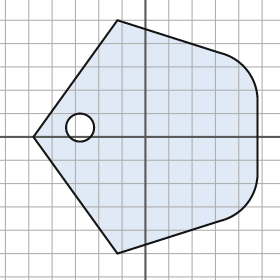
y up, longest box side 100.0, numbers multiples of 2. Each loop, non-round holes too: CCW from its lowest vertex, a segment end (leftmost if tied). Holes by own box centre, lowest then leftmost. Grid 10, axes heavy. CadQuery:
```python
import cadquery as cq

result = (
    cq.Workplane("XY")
    .moveTo(-12.0, -50.0)
    .lineTo(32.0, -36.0)
    .threePointArc((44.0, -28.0), (48.0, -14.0))
    .lineTo(48.0, 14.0)
    .threePointArc((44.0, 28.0), (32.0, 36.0))
    .lineTo(-12.0, 50.0)
    .lineTo(-48.0, 0.0)
    .close()
    .moveTo(-28.0, 4.0)
    .circle(6.0)
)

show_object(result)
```